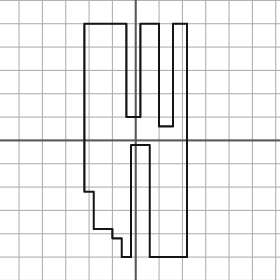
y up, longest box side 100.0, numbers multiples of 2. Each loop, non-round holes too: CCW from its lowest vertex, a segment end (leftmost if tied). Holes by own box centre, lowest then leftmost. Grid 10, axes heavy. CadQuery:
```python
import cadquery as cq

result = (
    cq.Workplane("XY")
    .moveTo(-6.0, -50.0)
    .lineTo(-2.0, -50.0)
    .lineTo(-2.0, -2.0)
    .lineTo(6.0, -2.0)
    .lineTo(6.0, -50.0)
    .lineTo(22.0, -50.0)
    .lineTo(22.0, 50.0)
    .lineTo(16.0, 50.0)
    .lineTo(16.0, 6.0)
    .lineTo(10.0, 6.0)
    .lineTo(10.0, 50.0)
    .lineTo(2.0, 50.0)
    .lineTo(2.0, 10.0)
    .lineTo(-4.0, 10.0)
    .lineTo(-4.0, 50.0)
    .lineTo(-22.0, 50.0)
    .lineTo(-22.0, -22.0)
    .lineTo(-18.0, -22.0)
    .lineTo(-18.0, -38.0)
    .lineTo(-10.0, -38.0)
    .lineTo(-10.0, -42.0)
    .lineTo(-6.0, -42.0)
    .close()
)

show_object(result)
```